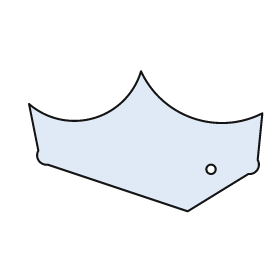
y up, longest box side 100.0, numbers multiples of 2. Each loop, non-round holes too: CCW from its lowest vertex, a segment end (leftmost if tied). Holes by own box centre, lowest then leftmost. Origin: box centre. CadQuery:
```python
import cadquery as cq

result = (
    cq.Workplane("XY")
    .moveTo(18.0, -30.0)
    .lineTo(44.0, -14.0)
    .threePointArc((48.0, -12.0), (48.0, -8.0))
    .lineTo(50.0, 12.0)
    .threePointArc((20.0, 10.0), (-2.0, 30.0))
    .threePointArc((-22.0, 10.0), (-50.0, 16.0))
    .lineTo(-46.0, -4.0)
    .threePointArc((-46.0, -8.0), (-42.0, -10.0))
    .close()
    .moveTo(28.0, -12.0)
    .circle(2.0)
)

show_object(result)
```